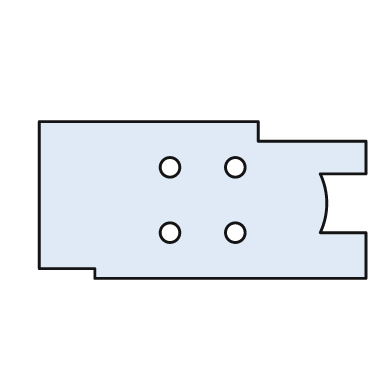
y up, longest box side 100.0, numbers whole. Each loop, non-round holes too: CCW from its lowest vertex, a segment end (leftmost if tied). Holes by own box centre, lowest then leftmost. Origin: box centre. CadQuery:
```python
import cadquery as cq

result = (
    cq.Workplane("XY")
    .moveTo(-33.0, -24.0)
    .lineTo(50.0, -24.0)
    .lineTo(50.0, -10.0)
    .lineTo(36.0, -10.0)
    .threePointArc((38.0, -1.0), (36.0, 8.0))
    .lineTo(50.0, 8.0)
    .lineTo(50.0, 18.0)
    .lineTo(17.0, 18.0)
    .lineTo(17.0, 24.0)
    .lineTo(-50.0, 24.0)
    .lineTo(-50.0, -21.0)
    .lineTo(-33.0, -21.0)
    .close()
    .moveTo(-10.0, -10.0)
    .circle(3.0)
    .moveTo(10.0, -10.0)
    .circle(3.0)
    .moveTo(-10.0, 10.0)
    .circle(3.0)
    .moveTo(10.0, 10.0)
    .circle(3.0)
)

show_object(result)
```